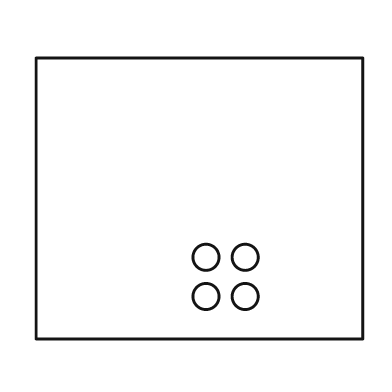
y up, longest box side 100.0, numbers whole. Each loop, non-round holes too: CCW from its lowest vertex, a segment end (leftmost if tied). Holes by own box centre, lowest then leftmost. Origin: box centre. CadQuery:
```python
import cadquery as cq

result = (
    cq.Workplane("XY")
    .moveTo(-50.0, -43.0)
    .lineTo(50.0, -43.0)
    .lineTo(50.0, 43.0)
    .lineTo(-50.0, 43.0)
    .close()
    .moveTo(2.0, -30.0)
    .circle(4.0)
    .moveTo(14.0, -30.0)
    .circle(4.0)
    .moveTo(2.0, -18.0)
    .circle(4.0)
    .moveTo(14.0, -18.0)
    .circle(4.0)
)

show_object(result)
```